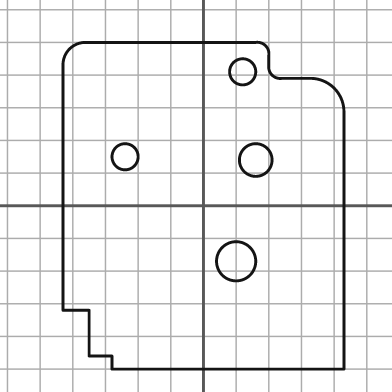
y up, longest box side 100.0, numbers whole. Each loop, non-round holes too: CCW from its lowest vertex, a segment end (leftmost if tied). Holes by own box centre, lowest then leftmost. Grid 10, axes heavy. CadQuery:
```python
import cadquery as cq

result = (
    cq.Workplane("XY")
    .moveTo(-28.0, -50.0)
    .lineTo(43.0, -50.0)
    .lineTo(43.0, 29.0)
    .threePointArc((40.0, 36.0), (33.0, 39.0))
    .lineTo(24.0, 39.0)
    .threePointArc((21.0, 40.0), (20.0, 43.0))
    .lineTo(20.0, 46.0)
    .threePointArc((19.0, 49.0), (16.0, 50.0))
    .lineTo(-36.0, 50.0)
    .threePointArc((-41.0, 48.0), (-43.0, 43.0))
    .lineTo(-43.0, -32.0)
    .lineTo(-35.0, -32.0)
    .lineTo(-35.0, -46.0)
    .lineTo(-28.0, -46.0)
    .close()
    .moveTo(10.0, -17.0)
    .circle(6.0)
    .moveTo(16.0, 14.0)
    .circle(5.0)
    .moveTo(-24.0, 15.0)
    .circle(4.0)
    .moveTo(12.0, 41.0)
    .circle(4.0)
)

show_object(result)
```